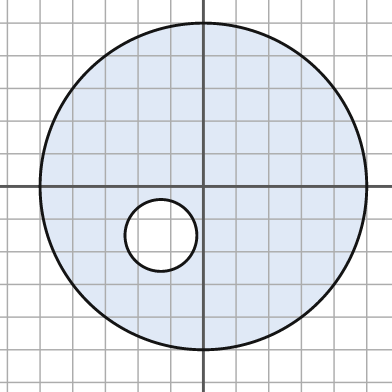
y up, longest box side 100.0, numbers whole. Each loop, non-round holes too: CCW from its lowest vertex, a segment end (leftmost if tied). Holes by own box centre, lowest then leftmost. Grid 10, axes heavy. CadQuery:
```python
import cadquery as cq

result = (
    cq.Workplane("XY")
    .moveTo(0.0, 0.0)
    .circle(50.0)
    .moveTo(-13.0, -15.0)
    .circle(11.0)
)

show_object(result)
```